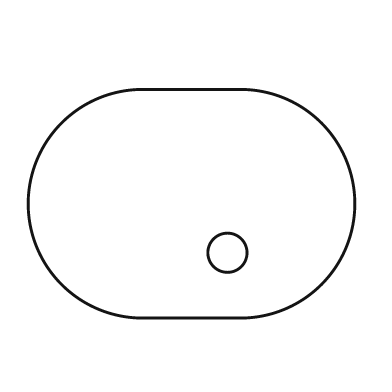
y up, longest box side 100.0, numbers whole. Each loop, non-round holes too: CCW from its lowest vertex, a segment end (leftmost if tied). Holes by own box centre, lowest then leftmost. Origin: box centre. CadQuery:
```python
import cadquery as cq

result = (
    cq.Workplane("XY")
    .moveTo(-15.0, -35.0)
    .lineTo(15.0, -35.0)
    .threePointArc((50.0, 0.0), (15.0, 35.0))
    .lineTo(-15.0, 35.0)
    .threePointArc((-50.0, 0.0), (-15.0, -35.0))
    .close()
    .moveTo(11.0, -15.0)
    .circle(6.0)
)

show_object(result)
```